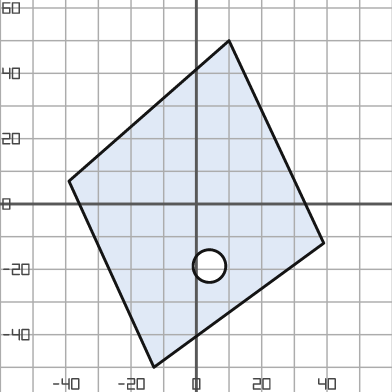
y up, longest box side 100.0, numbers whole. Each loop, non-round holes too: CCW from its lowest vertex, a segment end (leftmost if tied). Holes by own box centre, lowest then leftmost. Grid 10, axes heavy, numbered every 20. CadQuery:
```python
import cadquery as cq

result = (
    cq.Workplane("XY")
    .moveTo(-13.0, -50.0)
    .lineTo(39.0, -12.0)
    .lineTo(10.0, 50.0)
    .lineTo(-39.0, 7.0)
    .close()
    .moveTo(4.0, -19.0)
    .circle(5.0)
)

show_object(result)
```